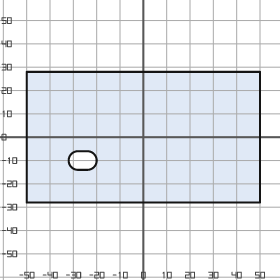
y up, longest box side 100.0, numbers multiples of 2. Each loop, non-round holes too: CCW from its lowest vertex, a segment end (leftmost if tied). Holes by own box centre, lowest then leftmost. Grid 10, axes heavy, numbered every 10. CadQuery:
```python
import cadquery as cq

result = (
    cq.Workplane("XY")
    .moveTo(-50.0, -28.0)
    .lineTo(50.0, -28.0)
    .lineTo(50.0, 28.0)
    .lineTo(-50.0, 28.0)
    .close()
    .moveTo(-28.0, -14.0)
    .lineTo(-24.0, -14.0)
    .threePointArc((-20.0, -10.0), (-24.0, -6.0))
    .lineTo(-28.0, -6.0)
    .threePointArc((-32.0, -10.0), (-28.0, -14.0))
    .close()
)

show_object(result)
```